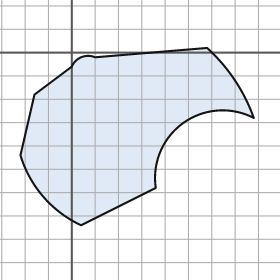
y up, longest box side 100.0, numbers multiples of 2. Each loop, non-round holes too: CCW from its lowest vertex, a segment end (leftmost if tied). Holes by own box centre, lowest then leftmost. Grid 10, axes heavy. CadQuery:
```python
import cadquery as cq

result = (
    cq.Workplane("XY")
    .moveTo(4.0, -74.0)
    .lineTo(36.0, -58.0)
    .threePointArc((48.0, -30.0), (78.0, -28.0))
    .threePointArc((70.0, -12.0), (58.0, 2.0))
    .lineTo(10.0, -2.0)
    .threePointArc((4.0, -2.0), (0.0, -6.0))
    .lineTo(-16.0, -18.0)
    .lineTo(-22.0, -44.0)
    .threePointArc((-12.0, -62.0), (4.0, -74.0))
    .close()
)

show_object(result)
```